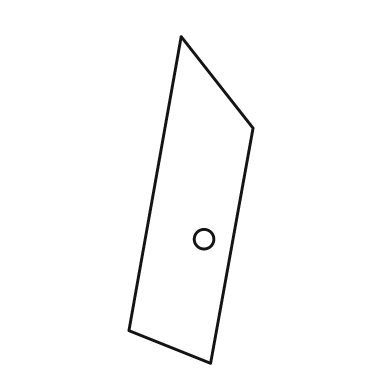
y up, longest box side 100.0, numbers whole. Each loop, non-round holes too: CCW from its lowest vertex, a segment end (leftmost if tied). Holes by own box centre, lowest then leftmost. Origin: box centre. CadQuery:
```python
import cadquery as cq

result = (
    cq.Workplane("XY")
    .moveTo(6.0, -50.0)
    .lineTo(19.0, 22.0)
    .lineTo(-3.0, 50.0)
    .lineTo(-19.0, -40.0)
    .close()
    .moveTo(4.0, -12.0)
    .circle(3.0)
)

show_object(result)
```